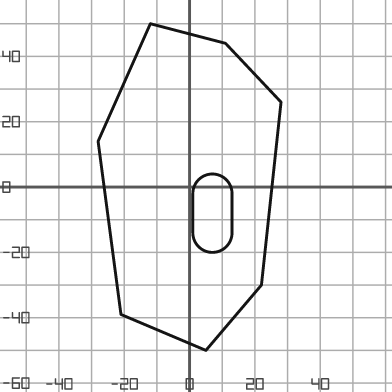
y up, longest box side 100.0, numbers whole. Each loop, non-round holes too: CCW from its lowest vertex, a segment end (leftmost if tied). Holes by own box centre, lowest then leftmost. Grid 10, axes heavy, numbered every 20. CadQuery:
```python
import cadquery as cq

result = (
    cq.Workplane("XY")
    .moveTo(5.0, -50.0)
    .lineTo(22.0, -30.0)
    .lineTo(28.0, 26.0)
    .lineTo(11.0, 44.0)
    .lineTo(-12.0, 50.0)
    .lineTo(-28.0, 14.0)
    .lineTo(-21.0, -39.0)
    .close()
    .moveTo(1.0, -14.0)
    .threePointArc((7.0, -20.0), (13.0, -14.0))
    .lineTo(13.0, -2.0)
    .threePointArc((7.0, 4.0), (1.0, -2.0))
    .close()
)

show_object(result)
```